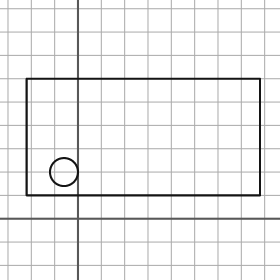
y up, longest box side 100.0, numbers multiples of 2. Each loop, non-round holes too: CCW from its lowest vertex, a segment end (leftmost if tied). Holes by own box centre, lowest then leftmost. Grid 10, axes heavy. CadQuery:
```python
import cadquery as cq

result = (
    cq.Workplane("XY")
    .moveTo(-22.0, 10.0)
    .lineTo(78.0, 10.0)
    .lineTo(78.0, 60.0)
    .lineTo(-22.0, 60.0)
    .close()
    .moveTo(-6.0, 20.0)
    .circle(6.0)
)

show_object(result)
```